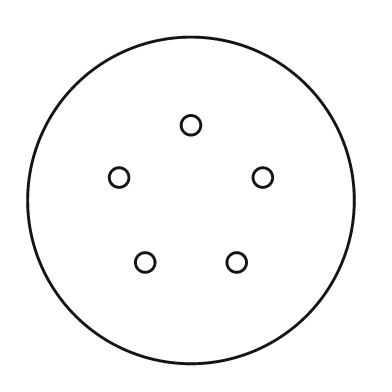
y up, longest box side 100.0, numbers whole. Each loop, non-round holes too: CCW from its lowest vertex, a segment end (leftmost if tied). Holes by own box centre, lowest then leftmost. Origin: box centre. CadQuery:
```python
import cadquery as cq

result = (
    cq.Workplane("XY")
    .moveTo(0.0, 0.0)
    .circle(50.0)
    .moveTo(-14.0, -19.0)
    .circle(3.0)
    .moveTo(14.0, -19.0)
    .circle(3.0)
    .moveTo(-22.0, 7.0)
    .circle(3.0)
    .moveTo(22.0, 7.0)
    .circle(3.0)
    .moveTo(0.0, 23.0)
    .circle(3.0)
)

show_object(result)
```